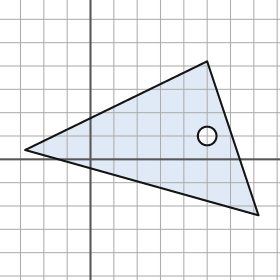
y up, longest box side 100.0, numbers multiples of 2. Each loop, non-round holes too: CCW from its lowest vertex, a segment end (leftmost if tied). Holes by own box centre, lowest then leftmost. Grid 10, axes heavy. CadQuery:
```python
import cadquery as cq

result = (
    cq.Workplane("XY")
    .moveTo(72.0, -24.0)
    .lineTo(50.0, 42.0)
    .lineTo(-28.0, 4.0)
    .close()
    .moveTo(50.0, 10.0)
    .circle(4.0)
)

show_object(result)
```